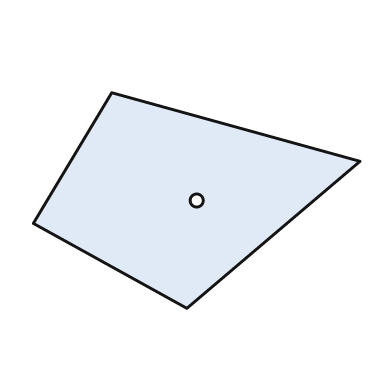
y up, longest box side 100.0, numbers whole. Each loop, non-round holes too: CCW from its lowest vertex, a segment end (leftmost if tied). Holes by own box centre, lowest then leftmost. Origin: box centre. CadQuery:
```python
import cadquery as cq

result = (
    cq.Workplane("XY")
    .moveTo(-3.0, -33.0)
    .lineTo(50.0, 12.0)
    .lineTo(-26.0, 33.0)
    .lineTo(-50.0, -7.0)
    .close()
    .moveTo(0.0, 0.0)
    .circle(2.0)
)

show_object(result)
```